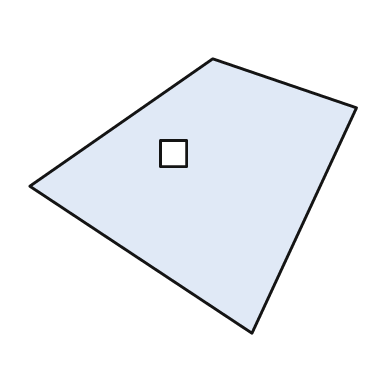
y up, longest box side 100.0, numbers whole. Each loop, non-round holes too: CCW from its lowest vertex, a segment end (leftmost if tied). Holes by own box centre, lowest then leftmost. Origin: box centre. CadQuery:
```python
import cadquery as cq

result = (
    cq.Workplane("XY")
    .moveTo(18.0, -42.0)
    .lineTo(50.0, 27.0)
    .lineTo(6.0, 42.0)
    .lineTo(-50.0, 3.0)
    .close()
    .moveTo(-10.0, 9.0)
    .lineTo(-2.0, 9.0)
    .lineTo(-2.0, 17.0)
    .lineTo(-10.0, 17.0)
    .close()
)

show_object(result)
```